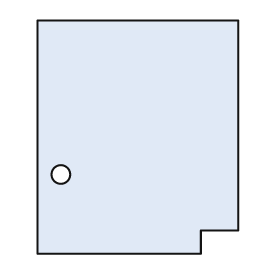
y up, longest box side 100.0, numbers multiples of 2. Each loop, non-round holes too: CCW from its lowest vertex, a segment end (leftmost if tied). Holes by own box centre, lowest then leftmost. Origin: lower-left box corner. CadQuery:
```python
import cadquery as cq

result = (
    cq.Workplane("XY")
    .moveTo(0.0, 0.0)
    .lineTo(70.0, 0.0)
    .lineTo(70.0, 10.0)
    .lineTo(86.0, 10.0)
    .lineTo(86.0, 100.0)
    .lineTo(0.0, 100.0)
    .close()
    .moveTo(10.0, 34.0)
    .circle(4.0)
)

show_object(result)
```